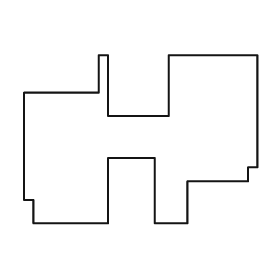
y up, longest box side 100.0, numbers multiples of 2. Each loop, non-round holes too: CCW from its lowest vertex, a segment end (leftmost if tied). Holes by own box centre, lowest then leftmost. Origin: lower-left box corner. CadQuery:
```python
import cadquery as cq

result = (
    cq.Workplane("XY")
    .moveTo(4.0, 0.0)
    .lineTo(36.0, 0.0)
    .lineTo(36.0, 28.0)
    .lineTo(56.0, 28.0)
    .lineTo(56.0, 0.0)
    .lineTo(70.0, 0.0)
    .lineTo(70.0, 18.0)
    .lineTo(96.0, 18.0)
    .lineTo(96.0, 24.0)
    .lineTo(100.0, 24.0)
    .lineTo(100.0, 72.0)
    .lineTo(62.0, 72.0)
    .lineTo(62.0, 46.0)
    .lineTo(36.0, 46.0)
    .lineTo(36.0, 72.0)
    .lineTo(32.0, 72.0)
    .lineTo(32.0, 56.0)
    .lineTo(0.0, 56.0)
    .lineTo(0.0, 10.0)
    .lineTo(4.0, 10.0)
    .close()
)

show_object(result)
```